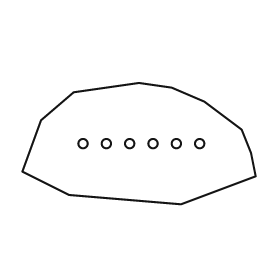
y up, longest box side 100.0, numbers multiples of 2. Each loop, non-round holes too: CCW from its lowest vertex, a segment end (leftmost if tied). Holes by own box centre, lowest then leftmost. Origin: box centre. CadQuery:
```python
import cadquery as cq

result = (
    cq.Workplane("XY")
    .moveTo(18.0, -26.0)
    .lineTo(50.0, -14.0)
    .lineTo(48.0, -4.0)
    .lineTo(44.0, 6.0)
    .lineTo(28.0, 18.0)
    .lineTo(14.0, 24.0)
    .lineTo(0.0, 26.0)
    .lineTo(-28.0, 22.0)
    .lineTo(-42.0, 10.0)
    .lineTo(-50.0, -12.0)
    .lineTo(-30.0, -22.0)
    .close()
    .moveTo(-24.0, 0.0)
    .circle(2.0)
    .moveTo(-14.0, 0.0)
    .circle(2.0)
    .moveTo(-4.0, 0.0)
    .circle(2.0)
    .moveTo(6.0, 0.0)
    .circle(2.0)
    .moveTo(16.0, 0.0)
    .circle(2.0)
    .moveTo(26.0, 0.0)
    .circle(2.0)
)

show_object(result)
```